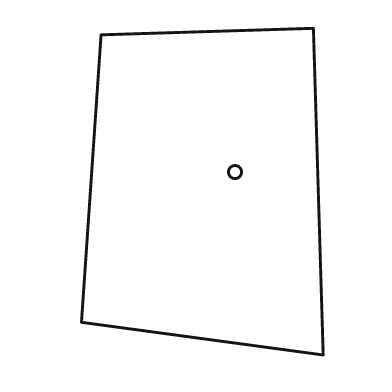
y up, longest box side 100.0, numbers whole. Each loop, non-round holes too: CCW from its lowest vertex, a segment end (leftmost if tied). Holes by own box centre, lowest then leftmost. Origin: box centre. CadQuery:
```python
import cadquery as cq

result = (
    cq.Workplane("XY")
    .moveTo(37.0, -50.0)
    .lineTo(34.0, 50.0)
    .lineTo(-31.0, 48.0)
    .lineTo(-37.0, -40.0)
    .close()
    .moveTo(10.0, 6.0)
    .circle(2.0)
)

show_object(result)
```